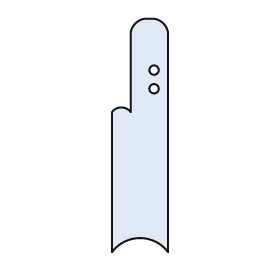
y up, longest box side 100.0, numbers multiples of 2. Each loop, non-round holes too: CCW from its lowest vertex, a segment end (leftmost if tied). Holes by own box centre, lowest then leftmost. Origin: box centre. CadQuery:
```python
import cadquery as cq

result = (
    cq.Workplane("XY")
    .moveTo(-12.0, -50.0)
    .threePointArc((0.0, -44.0), (12.0, -50.0))
    .lineTo(12.0, 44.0)
    .threePointArc((10.0, 48.0), (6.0, 50.0))
    .lineTo(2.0, 50.0)
    .threePointArc((-2.0, 48.0), (-4.0, 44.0))
    .lineTo(-4.0, 10.0)
    .threePointArc((-8.0, 12.0), (-12.0, 10.0))
    .close()
    .moveTo(6.0, 20.0)
    .circle(2.0)
    .moveTo(6.0, 28.0)
    .circle(2.0)
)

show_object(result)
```